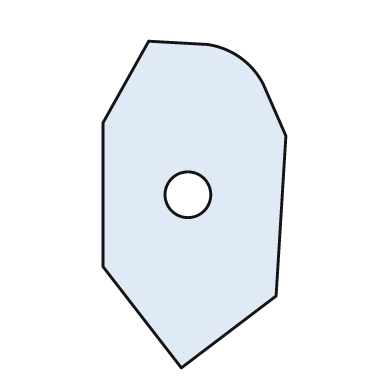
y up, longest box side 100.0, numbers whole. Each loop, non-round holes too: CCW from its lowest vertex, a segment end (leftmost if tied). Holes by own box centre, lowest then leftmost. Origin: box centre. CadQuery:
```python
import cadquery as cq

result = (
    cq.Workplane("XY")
    .moveTo(-4.0, -50.0)
    .lineTo(25.0, -28.0)
    .lineTo(28.0, 21.0)
    .lineTo(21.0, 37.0)
    .threePointArc((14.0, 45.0), (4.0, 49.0))
    .lineTo(-14.0, 50.0)
    .lineTo(-28.0, 25.0)
    .lineTo(-28.0, -19.0)
    .close()
    .moveTo(-2.0, 3.0)
    .circle(7.0)
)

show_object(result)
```